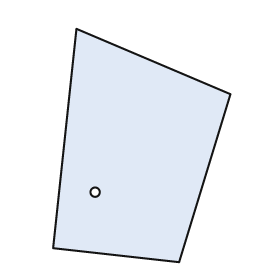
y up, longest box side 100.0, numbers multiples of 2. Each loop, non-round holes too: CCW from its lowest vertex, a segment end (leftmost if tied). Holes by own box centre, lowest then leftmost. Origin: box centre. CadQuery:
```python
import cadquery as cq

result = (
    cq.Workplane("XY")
    .moveTo(16.0, -50.0)
    .lineTo(38.0, 22.0)
    .lineTo(-28.0, 50.0)
    .lineTo(-38.0, -44.0)
    .close()
    .moveTo(-20.0, -20.0)
    .circle(2.0)
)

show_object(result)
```